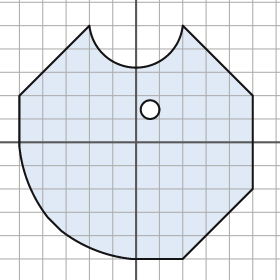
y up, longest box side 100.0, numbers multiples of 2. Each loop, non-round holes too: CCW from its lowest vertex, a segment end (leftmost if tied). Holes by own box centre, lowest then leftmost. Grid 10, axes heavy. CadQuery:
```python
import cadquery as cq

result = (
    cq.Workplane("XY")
    .moveTo(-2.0, -50.0)
    .lineTo(20.0, -50.0)
    .lineTo(50.0, -20.0)
    .lineTo(50.0, 20.0)
    .lineTo(20.0, 50.0)
    .threePointArc((0.0, 32.0), (-20.0, 50.0))
    .lineTo(-50.0, 20.0)
    .lineTo(-50.0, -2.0)
    .threePointArc((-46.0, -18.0), (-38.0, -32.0))
    .lineTo(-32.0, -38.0)
    .threePointArc((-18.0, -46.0), (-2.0, -50.0))
    .close()
    .moveTo(6.0, 14.0)
    .circle(4.0)
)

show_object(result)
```